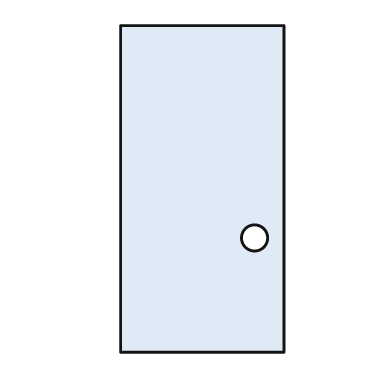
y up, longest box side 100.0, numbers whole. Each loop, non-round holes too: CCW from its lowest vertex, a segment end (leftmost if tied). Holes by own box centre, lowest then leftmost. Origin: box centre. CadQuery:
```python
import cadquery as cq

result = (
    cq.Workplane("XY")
    .moveTo(-25.0, -50.0)
    .lineTo(25.0, -50.0)
    .lineTo(25.0, 50.0)
    .lineTo(-25.0, 50.0)
    .close()
    .moveTo(16.0, -15.0)
    .circle(4.0)
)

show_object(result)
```